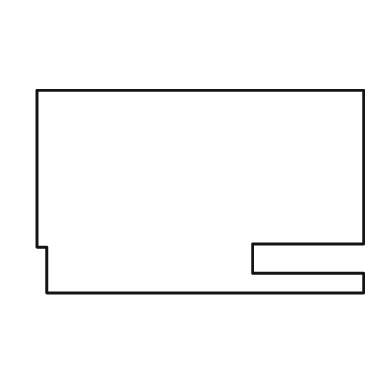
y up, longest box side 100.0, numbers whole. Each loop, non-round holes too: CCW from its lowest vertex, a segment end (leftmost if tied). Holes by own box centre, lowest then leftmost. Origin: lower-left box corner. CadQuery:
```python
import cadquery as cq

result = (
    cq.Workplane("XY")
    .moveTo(3.0, 0.0)
    .lineTo(100.0, 0.0)
    .lineTo(100.0, 6.0)
    .lineTo(66.0, 6.0)
    .lineTo(66.0, 15.0)
    .lineTo(100.0, 15.0)
    .lineTo(100.0, 62.0)
    .lineTo(0.0, 62.0)
    .lineTo(0.0, 14.0)
    .lineTo(3.0, 14.0)
    .close()
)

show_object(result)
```